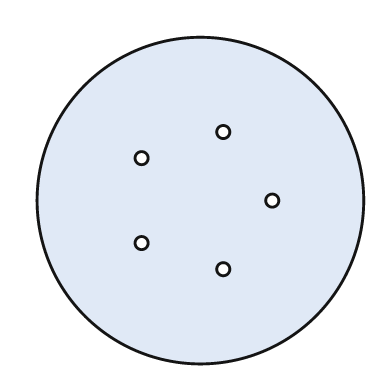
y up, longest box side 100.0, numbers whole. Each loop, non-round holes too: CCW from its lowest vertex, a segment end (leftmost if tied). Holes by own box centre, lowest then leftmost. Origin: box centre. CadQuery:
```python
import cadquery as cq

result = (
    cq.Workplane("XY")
    .moveTo(0.0, 0.0)
    .circle(50.0)
    .moveTo(7.0, -21.0)
    .circle(2.0)
    .moveTo(-18.0, -13.0)
    .circle(2.0)
    .moveTo(22.0, 0.0)
    .circle(2.0)
    .moveTo(-18.0, 13.0)
    .circle(2.0)
    .moveTo(7.0, 21.0)
    .circle(2.0)
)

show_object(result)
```